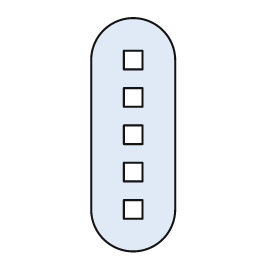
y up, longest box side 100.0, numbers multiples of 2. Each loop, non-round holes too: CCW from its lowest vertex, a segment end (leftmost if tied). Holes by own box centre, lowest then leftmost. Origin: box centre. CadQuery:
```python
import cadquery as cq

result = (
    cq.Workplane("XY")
    .moveTo(-18.0, -32.0)
    .threePointArc((0.0, -50.0), (18.0, -32.0))
    .lineTo(18.0, 32.0)
    .threePointArc((0.0, 50.0), (-18.0, 32.0))
    .close()
    .moveTo(-4.0, -36.0)
    .lineTo(4.0, -36.0)
    .lineTo(4.0, -28.0)
    .lineTo(-4.0, -28.0)
    .close()
    .moveTo(-4.0, -20.0)
    .lineTo(4.0, -20.0)
    .lineTo(4.0, -12.0)
    .lineTo(-4.0, -12.0)
    .close()
    .moveTo(-4.0, -4.0)
    .lineTo(4.0, -4.0)
    .lineTo(4.0, 4.0)
    .lineTo(-4.0, 4.0)
    .close()
    .moveTo(-4.0, 12.0)
    .lineTo(4.0, 12.0)
    .lineTo(4.0, 20.0)
    .lineTo(-4.0, 20.0)
    .close()
    .moveTo(-4.0, 28.0)
    .lineTo(4.0, 28.0)
    .lineTo(4.0, 36.0)
    .lineTo(-4.0, 36.0)
    .close()
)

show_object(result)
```